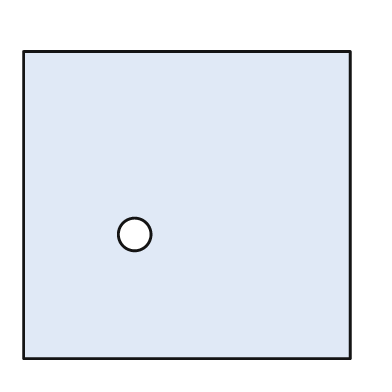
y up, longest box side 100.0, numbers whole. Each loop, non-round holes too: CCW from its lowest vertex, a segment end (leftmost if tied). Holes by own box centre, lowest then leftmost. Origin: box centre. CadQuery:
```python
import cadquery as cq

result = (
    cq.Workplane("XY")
    .moveTo(-50.0, -47.0)
    .lineTo(50.0, -47.0)
    .lineTo(50.0, 47.0)
    .lineTo(-50.0, 47.0)
    .close()
    .moveTo(-16.0, -9.0)
    .circle(5.0)
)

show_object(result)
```